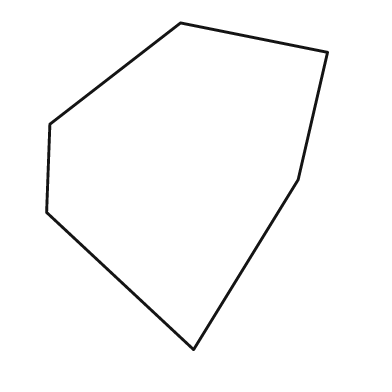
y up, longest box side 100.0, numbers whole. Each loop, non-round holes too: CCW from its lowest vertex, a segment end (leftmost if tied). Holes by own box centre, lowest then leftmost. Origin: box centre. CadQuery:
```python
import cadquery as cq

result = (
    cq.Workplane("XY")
    .moveTo(2.0, -50.0)
    .lineTo(34.0, 2.0)
    .lineTo(43.0, 41.0)
    .lineTo(-2.0, 50.0)
    .lineTo(-42.0, 19.0)
    .lineTo(-43.0, -8.0)
    .close()
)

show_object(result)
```